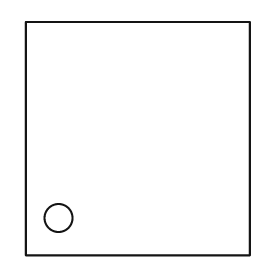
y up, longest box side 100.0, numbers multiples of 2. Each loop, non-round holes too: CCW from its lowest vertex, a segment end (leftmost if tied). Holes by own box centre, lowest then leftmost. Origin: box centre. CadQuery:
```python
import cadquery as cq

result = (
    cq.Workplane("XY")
    .moveTo(-48.0, -50.0)
    .lineTo(48.0, -50.0)
    .lineTo(48.0, 50.0)
    .lineTo(-48.0, 50.0)
    .close()
    .moveTo(-34.0, -34.0)
    .circle(6.0)
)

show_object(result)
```